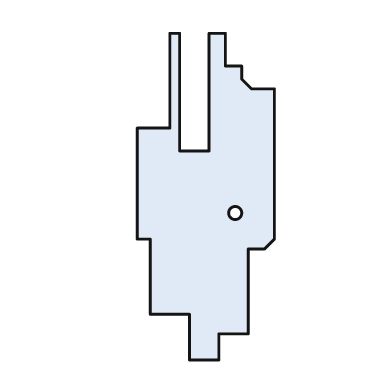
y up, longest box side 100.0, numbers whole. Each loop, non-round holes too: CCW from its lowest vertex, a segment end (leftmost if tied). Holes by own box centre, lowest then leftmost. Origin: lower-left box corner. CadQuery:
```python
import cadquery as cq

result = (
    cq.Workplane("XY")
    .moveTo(16.0, 0.0)
    .lineTo(25.0, 0.0)
    .lineTo(25.0, 8.0)
    .lineTo(34.0, 8.0)
    .lineTo(34.0, 34.0)
    .lineTo(39.0, 34.0)
    .lineTo(42.0, 37.0)
    .lineTo(42.0, 83.0)
    .lineTo(35.0, 83.0)
    .lineTo(32.0, 86.0)
    .lineTo(32.0, 90.0)
    .lineTo(27.0, 90.0)
    .lineTo(27.0, 100.0)
    .lineTo(22.0, 100.0)
    .lineTo(22.0, 64.0)
    .lineTo(13.0, 64.0)
    .lineTo(13.0, 100.0)
    .lineTo(10.0, 100.0)
    .lineTo(10.0, 71.0)
    .lineTo(0.0, 71.0)
    .lineTo(0.0, 37.0)
    .lineTo(4.0, 37.0)
    .lineTo(4.0, 14.0)
    .lineTo(16.0, 14.0)
    .close()
    .moveTo(30.0, 45.0)
    .circle(2.0)
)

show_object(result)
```